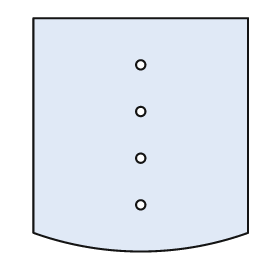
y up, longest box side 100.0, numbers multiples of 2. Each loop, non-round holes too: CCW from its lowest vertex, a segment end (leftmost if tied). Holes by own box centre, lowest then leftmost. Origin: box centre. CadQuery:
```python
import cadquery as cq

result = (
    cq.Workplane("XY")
    .moveTo(-46.0, -42.0)
    .threePointArc((0.0, -50.0), (46.0, -42.0))
    .lineTo(46.0, 50.0)
    .lineTo(-46.0, 50.0)
    .close()
    .moveTo(0.0, -30.0)
    .circle(2.0)
    .moveTo(0.0, -10.0)
    .circle(2.0)
    .moveTo(0.0, 10.0)
    .circle(2.0)
    .moveTo(0.0, 30.0)
    .circle(2.0)
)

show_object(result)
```